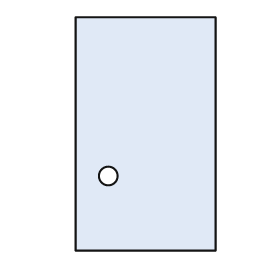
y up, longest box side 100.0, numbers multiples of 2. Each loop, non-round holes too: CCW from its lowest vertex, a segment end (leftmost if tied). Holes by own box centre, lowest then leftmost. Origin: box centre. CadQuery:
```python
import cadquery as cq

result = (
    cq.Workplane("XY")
    .moveTo(-30.0, -50.0)
    .lineTo(30.0, -50.0)
    .lineTo(30.0, 50.0)
    .lineTo(-30.0, 50.0)
    .close()
    .moveTo(-16.0, -18.0)
    .circle(4.0)
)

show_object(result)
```